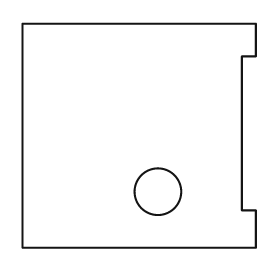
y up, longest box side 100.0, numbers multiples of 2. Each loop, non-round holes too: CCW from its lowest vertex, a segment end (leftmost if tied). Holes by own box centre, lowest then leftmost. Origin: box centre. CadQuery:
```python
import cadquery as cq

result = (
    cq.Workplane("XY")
    .moveTo(-50.0, -48.0)
    .lineTo(50.0, -48.0)
    .lineTo(50.0, -32.0)
    .lineTo(44.0, -32.0)
    .lineTo(44.0, 34.0)
    .lineTo(50.0, 34.0)
    .lineTo(50.0, 48.0)
    .lineTo(-50.0, 48.0)
    .close()
    .moveTo(8.0, -24.0)
    .circle(10.0)
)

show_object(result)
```